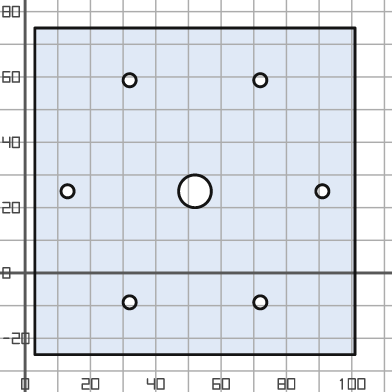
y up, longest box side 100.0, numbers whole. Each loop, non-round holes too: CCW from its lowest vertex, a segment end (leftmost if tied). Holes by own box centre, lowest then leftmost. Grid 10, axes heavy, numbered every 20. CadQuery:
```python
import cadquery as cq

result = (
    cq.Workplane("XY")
    .moveTo(3.0, -25.0)
    .lineTo(101.0, -25.0)
    .lineTo(101.0, 75.0)
    .lineTo(3.0, 75.0)
    .close()
    .moveTo(32.0, -9.0)
    .circle(2.0)
    .moveTo(72.0, -9.0)
    .circle(2.0)
    .moveTo(13.0, 25.0)
    .circle(2.0)
    .moveTo(52.0, 25.0)
    .circle(5.0)
    .moveTo(91.0, 25.0)
    .circle(2.0)
    .moveTo(32.0, 59.0)
    .circle(2.0)
    .moveTo(72.0, 59.0)
    .circle(2.0)
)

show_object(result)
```